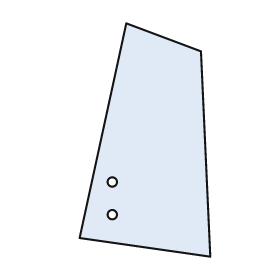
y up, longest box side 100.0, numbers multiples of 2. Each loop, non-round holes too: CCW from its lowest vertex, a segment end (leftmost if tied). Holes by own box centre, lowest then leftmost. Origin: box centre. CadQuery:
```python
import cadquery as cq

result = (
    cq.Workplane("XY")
    .moveTo(28.0, -50.0)
    .lineTo(24.0, 38.0)
    .lineTo(-8.0, 50.0)
    .lineTo(-28.0, -42.0)
    .close()
    .moveTo(-14.0, -32.0)
    .circle(2.0)
    .moveTo(-14.0, -18.0)
    .circle(2.0)
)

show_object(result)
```